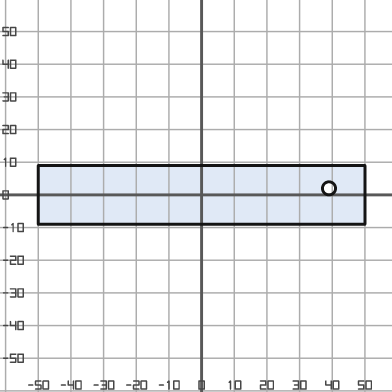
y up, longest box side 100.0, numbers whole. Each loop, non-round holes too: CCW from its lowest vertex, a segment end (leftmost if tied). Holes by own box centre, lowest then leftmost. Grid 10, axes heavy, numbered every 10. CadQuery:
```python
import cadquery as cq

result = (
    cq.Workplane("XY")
    .moveTo(-50.0, -9.0)
    .lineTo(50.0, -9.0)
    .lineTo(50.0, 9.0)
    .lineTo(-50.0, 9.0)
    .close()
    .moveTo(39.0, 2.0)
    .circle(2.0)
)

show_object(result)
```